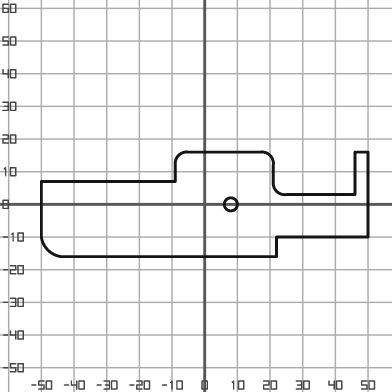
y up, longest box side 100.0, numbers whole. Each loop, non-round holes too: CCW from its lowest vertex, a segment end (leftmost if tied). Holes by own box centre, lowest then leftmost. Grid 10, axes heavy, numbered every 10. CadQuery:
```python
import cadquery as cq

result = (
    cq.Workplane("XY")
    .moveTo(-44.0, -16.0)
    .lineTo(22.0, -16.0)
    .lineTo(22.0, -10.0)
    .lineTo(50.0, -10.0)
    .lineTo(50.0, 16.0)
    .lineTo(46.0, 16.0)
    .lineTo(46.0, 3.0)
    .lineTo(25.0, 3.0)
    .threePointArc((22.0, 4.0), (21.0, 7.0))
    .lineTo(21.0, 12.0)
    .threePointArc((20.0, 15.0), (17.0, 16.0))
    .lineTo(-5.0, 16.0)
    .threePointArc((-8.0, 15.0), (-9.0, 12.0))
    .lineTo(-9.0, 7.0)
    .lineTo(-50.0, 7.0)
    .lineTo(-50.0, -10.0)
    .threePointArc((-48.0, -14.0), (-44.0, -16.0))
    .close()
    .moveTo(8.0, 0.0)
    .circle(2.0)
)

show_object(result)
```